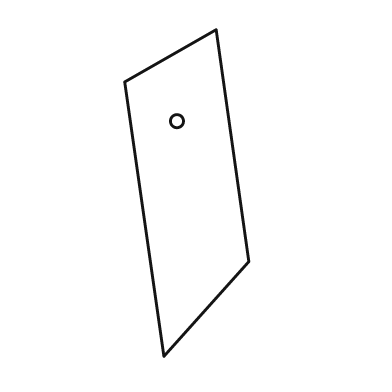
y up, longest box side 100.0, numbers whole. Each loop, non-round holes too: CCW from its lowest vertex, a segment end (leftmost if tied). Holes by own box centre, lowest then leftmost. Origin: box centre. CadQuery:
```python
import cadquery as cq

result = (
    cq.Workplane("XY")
    .moveTo(-7.0, -50.0)
    .lineTo(19.0, -21.0)
    .lineTo(9.0, 50.0)
    .lineTo(-19.0, 34.0)
    .close()
    .moveTo(-3.0, 22.0)
    .circle(2.0)
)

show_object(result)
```